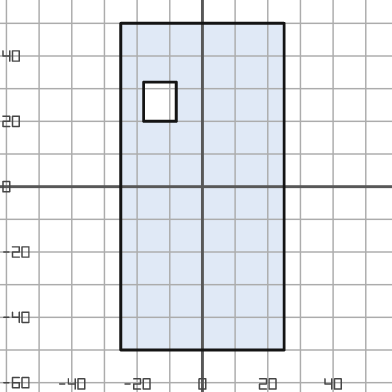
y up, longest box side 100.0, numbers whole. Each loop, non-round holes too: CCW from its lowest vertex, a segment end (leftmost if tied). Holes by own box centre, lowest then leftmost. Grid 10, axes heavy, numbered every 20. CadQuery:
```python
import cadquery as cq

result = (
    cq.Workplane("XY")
    .moveTo(-25.0, -50.0)
    .lineTo(25.0, -50.0)
    .lineTo(25.0, 50.0)
    .lineTo(-25.0, 50.0)
    .close()
    .moveTo(-18.0, 20.0)
    .lineTo(-8.0, 20.0)
    .lineTo(-8.0, 32.0)
    .lineTo(-18.0, 32.0)
    .close()
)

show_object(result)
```